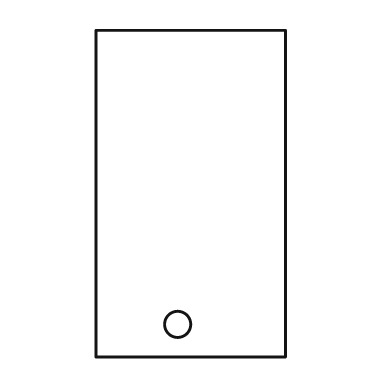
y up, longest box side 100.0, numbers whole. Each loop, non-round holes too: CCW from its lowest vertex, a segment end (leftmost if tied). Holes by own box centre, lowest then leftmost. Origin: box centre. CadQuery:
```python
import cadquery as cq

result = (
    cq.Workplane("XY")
    .moveTo(-29.0, -50.0)
    .lineTo(29.0, -50.0)
    .lineTo(29.0, 50.0)
    .lineTo(-29.0, 50.0)
    .close()
    .moveTo(-4.0, -40.0)
    .circle(4.0)
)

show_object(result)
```